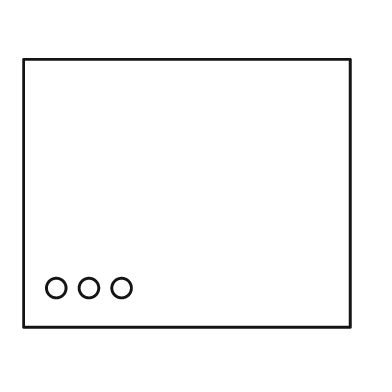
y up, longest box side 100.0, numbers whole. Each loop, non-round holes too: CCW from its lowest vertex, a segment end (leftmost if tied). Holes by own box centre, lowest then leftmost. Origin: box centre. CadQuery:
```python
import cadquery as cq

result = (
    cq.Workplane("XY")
    .moveTo(-50.0, -41.0)
    .lineTo(50.0, -41.0)
    .lineTo(50.0, 41.0)
    .lineTo(-50.0, 41.0)
    .close()
    .moveTo(-40.0, -29.0)
    .circle(3.0)
    .moveTo(-30.0, -29.0)
    .circle(3.0)
    .moveTo(-20.0, -29.0)
    .circle(3.0)
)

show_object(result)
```